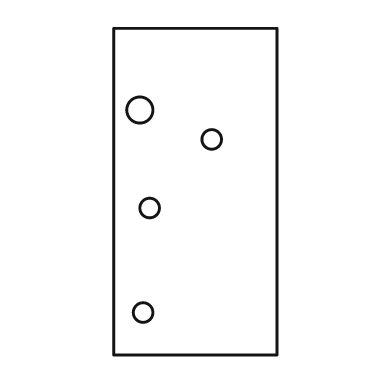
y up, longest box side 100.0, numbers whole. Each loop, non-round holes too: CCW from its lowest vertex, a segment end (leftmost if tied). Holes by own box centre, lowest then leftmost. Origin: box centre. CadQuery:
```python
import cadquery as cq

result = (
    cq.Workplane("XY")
    .moveTo(-25.0, -50.0)
    .lineTo(25.0, -50.0)
    .lineTo(25.0, 50.0)
    .lineTo(-25.0, 50.0)
    .close()
    .moveTo(-16.0, -37.0)
    .circle(3.0)
    .moveTo(-14.0, -5.0)
    .circle(3.0)
    .moveTo(5.0, 16.0)
    .circle(3.0)
    .moveTo(-17.0, 25.0)
    .circle(4.0)
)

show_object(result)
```